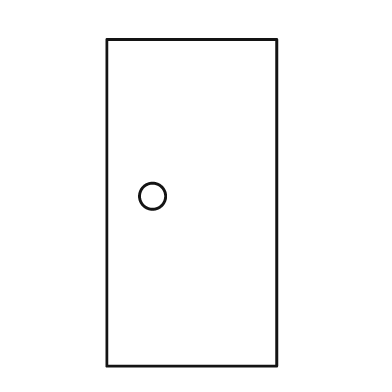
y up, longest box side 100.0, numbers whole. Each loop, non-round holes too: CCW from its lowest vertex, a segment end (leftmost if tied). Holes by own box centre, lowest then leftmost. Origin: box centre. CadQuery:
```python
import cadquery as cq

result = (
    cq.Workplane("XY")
    .moveTo(-26.0, -50.0)
    .lineTo(26.0, -50.0)
    .lineTo(26.0, 50.0)
    .lineTo(-26.0, 50.0)
    .close()
    .moveTo(-12.0, 2.0)
    .circle(4.0)
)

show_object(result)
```